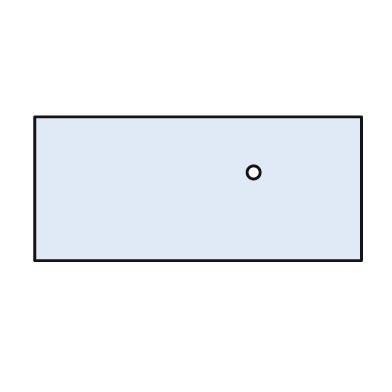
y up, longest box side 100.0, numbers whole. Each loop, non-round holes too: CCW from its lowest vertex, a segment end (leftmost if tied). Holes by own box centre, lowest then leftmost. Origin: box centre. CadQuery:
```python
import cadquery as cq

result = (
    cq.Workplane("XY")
    .moveTo(-50.0, -22.0)
    .lineTo(50.0, -22.0)
    .lineTo(50.0, 22.0)
    .lineTo(-50.0, 22.0)
    .close()
    .moveTo(17.0, 5.0)
    .circle(2.0)
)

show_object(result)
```